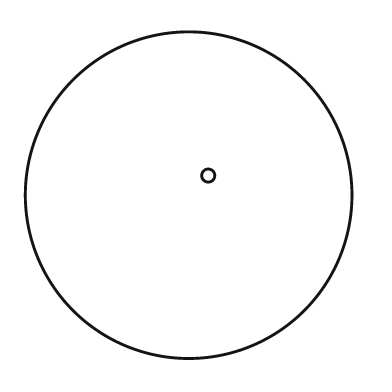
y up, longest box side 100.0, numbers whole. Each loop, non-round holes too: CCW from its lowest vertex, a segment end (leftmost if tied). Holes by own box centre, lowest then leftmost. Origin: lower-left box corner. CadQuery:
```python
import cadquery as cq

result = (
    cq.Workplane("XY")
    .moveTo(50.0, 50.0)
    .circle(50.0)
    .moveTo(56.0, 56.0)
    .circle(2.0)
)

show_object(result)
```